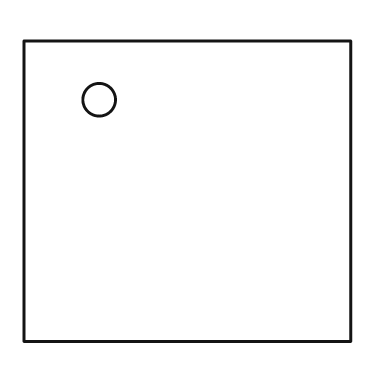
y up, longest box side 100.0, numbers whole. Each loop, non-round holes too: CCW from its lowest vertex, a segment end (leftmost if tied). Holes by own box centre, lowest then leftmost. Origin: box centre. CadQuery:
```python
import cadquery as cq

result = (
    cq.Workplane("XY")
    .moveTo(-50.0, -46.0)
    .lineTo(50.0, -46.0)
    .lineTo(50.0, 46.0)
    .lineTo(-50.0, 46.0)
    .close()
    .moveTo(-27.0, 28.0)
    .circle(5.0)
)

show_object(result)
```